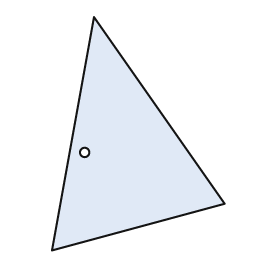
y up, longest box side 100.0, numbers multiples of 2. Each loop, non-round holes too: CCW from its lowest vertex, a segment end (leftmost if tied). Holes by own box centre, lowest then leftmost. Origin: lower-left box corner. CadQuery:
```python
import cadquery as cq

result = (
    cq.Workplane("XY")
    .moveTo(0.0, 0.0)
    .lineTo(74.0, 20.0)
    .lineTo(18.0, 100.0)
    .close()
    .moveTo(14.0, 42.0)
    .circle(2.0)
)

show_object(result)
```